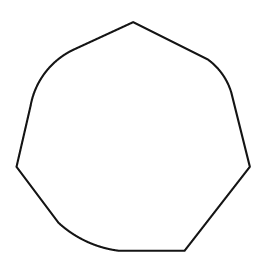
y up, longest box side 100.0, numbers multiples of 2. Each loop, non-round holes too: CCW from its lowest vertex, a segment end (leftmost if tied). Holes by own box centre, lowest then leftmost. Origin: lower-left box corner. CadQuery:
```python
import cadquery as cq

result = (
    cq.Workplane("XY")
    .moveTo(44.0, 0.0)
    .lineTo(72.0, 0.0)
    .lineTo(100.0, 36.0)
    .lineTo(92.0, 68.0)
    .threePointArc((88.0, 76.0), (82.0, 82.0))
    .lineTo(50.0, 98.0)
    .lineTo(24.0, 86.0)
    .threePointArc((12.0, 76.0), (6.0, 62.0))
    .lineTo(0.0, 36.0)
    .lineTo(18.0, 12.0)
    .threePointArc((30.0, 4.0), (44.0, 0.0))
    .close()
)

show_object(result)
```